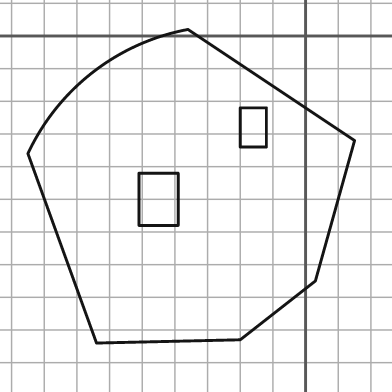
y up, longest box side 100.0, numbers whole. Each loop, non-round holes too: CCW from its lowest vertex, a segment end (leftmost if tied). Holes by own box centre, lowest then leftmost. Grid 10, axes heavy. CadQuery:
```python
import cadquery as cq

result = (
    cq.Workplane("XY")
    .moveTo(-64.0, -94.0)
    .lineTo(-20.0, -93.0)
    .lineTo(3.0, -75.0)
    .lineTo(15.0, -32.0)
    .lineTo(-36.0, 2.0)
    .threePointArc((-65.0, -11.0), (-85.0, -36.0))
    .close()
    .moveTo(-51.0, -58.0)
    .lineTo(-39.0, -58.0)
    .lineTo(-39.0, -42.0)
    .lineTo(-51.0, -42.0)
    .close()
    .moveTo(-20.0, -34.0)
    .lineTo(-12.0, -34.0)
    .lineTo(-12.0, -22.0)
    .lineTo(-20.0, -22.0)
    .close()
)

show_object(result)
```